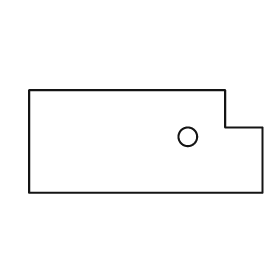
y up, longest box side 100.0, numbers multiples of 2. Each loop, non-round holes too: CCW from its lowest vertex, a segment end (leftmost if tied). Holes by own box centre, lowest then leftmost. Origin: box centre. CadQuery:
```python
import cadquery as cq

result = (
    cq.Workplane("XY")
    .moveTo(-50.0, -22.0)
    .lineTo(50.0, -22.0)
    .lineTo(50.0, 6.0)
    .lineTo(34.0, 6.0)
    .lineTo(34.0, 22.0)
    .lineTo(-50.0, 22.0)
    .close()
    .moveTo(18.0, 2.0)
    .circle(4.0)
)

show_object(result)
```